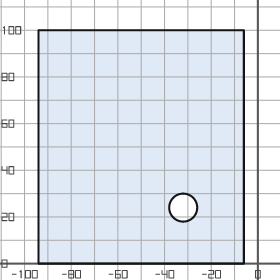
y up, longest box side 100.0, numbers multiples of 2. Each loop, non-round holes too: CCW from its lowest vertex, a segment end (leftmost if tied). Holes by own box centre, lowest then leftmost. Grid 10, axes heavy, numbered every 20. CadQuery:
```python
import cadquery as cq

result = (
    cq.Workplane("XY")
    .moveTo(-94.0, 0.0)
    .lineTo(-6.0, 0.0)
    .lineTo(-6.0, 100.0)
    .lineTo(-94.0, 100.0)
    .close()
    .moveTo(-32.0, 24.0)
    .circle(6.0)
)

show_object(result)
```